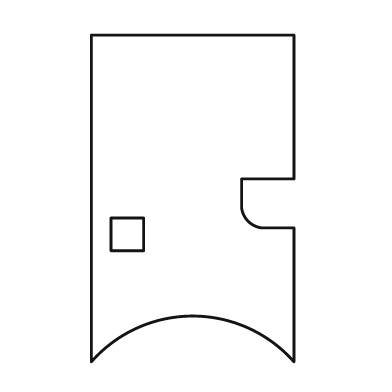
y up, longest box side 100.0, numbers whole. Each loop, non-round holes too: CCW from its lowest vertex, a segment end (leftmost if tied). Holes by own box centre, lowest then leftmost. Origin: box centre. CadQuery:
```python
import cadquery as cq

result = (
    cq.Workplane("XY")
    .moveTo(-31.0, -50.0)
    .threePointArc((0.0, -36.0), (31.0, -50.0))
    .lineTo(31.0, -9.0)
    .lineTo(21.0, -9.0)
    .threePointArc((17.0, -7.0), (15.0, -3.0))
    .lineTo(15.0, 6.0)
    .lineTo(31.0, 6.0)
    .lineTo(31.0, 50.0)
    .lineTo(-31.0, 50.0)
    .close()
    .moveTo(-25.0, -16.0)
    .lineTo(-15.0, -16.0)
    .lineTo(-15.0, -6.0)
    .lineTo(-25.0, -6.0)
    .close()
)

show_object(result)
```